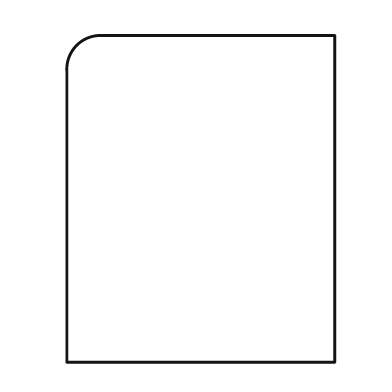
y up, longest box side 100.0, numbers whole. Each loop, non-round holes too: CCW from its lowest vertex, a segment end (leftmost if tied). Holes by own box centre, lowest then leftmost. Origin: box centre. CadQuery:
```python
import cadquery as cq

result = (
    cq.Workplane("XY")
    .moveTo(-41.0, -50.0)
    .lineTo(41.0, -50.0)
    .lineTo(41.0, 50.0)
    .lineTo(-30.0, 50.0)
    .threePointArc((-38.0, 47.0), (-41.0, 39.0))
    .close()
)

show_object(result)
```